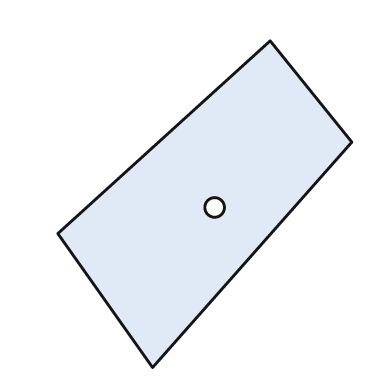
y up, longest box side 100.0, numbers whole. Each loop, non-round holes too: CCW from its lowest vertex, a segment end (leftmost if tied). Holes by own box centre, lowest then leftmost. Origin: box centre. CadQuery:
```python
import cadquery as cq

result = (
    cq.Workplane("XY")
    .moveTo(-16.0, -50.0)
    .lineTo(45.0, 19.0)
    .lineTo(20.0, 50.0)
    .lineTo(-45.0, -9.0)
    .close()
    .moveTo(3.0, -1.0)
    .circle(3.0)
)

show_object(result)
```